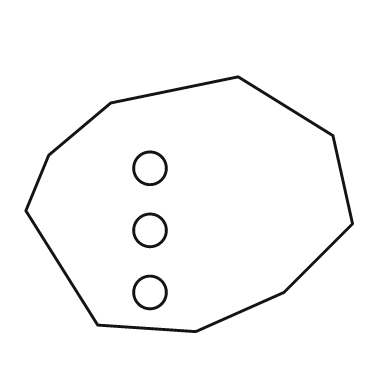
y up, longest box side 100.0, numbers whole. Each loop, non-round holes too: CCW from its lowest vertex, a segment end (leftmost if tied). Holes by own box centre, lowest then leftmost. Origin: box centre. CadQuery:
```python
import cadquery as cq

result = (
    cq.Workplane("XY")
    .moveTo(2.0, -39.0)
    .lineTo(29.0, -27.0)
    .lineTo(50.0, -6.0)
    .lineTo(44.0, 21.0)
    .lineTo(15.0, 39.0)
    .lineTo(-24.0, 31.0)
    .lineTo(-43.0, 15.0)
    .lineTo(-50.0, -2.0)
    .lineTo(-28.0, -37.0)
    .close()
    .moveTo(-12.0, -27.0)
    .circle(5.0)
    .moveTo(-12.0, -8.0)
    .circle(5.0)
    .moveTo(-12.0, 11.0)
    .circle(5.0)
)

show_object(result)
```